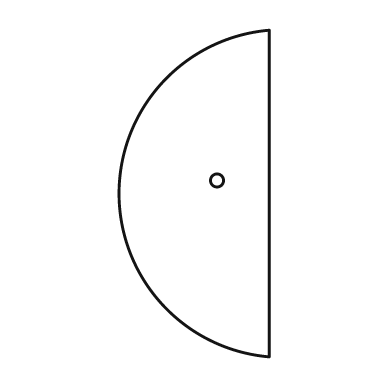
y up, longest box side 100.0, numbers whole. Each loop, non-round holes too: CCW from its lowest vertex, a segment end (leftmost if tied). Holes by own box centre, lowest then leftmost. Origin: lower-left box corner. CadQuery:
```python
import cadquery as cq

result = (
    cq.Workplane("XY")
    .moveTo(46.0, 0.0)
    .lineTo(46.0, 100.0)
    .threePointArc((0.0, 50.0), (46.0, 0.0))
    .close()
    .moveTo(30.0, 54.0)
    .circle(2.0)
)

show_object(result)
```